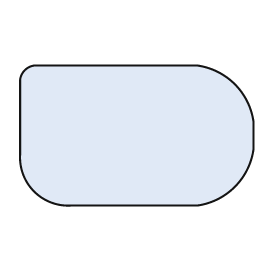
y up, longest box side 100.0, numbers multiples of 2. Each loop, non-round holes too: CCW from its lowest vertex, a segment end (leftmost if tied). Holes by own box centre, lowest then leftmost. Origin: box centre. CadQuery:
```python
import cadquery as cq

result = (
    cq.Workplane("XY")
    .moveTo(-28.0, -30.0)
    .lineTo(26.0, -30.0)
    .threePointArc((42.0, -22.0), (50.0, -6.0))
    .lineTo(50.0, 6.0)
    .threePointArc((42.0, 22.0), (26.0, 30.0))
    .lineTo(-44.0, 30.0)
    .threePointArc((-48.0, 28.0), (-50.0, 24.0))
    .lineTo(-50.0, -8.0)
    .threePointArc((-44.0, -24.0), (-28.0, -30.0))
    .close()
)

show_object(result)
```